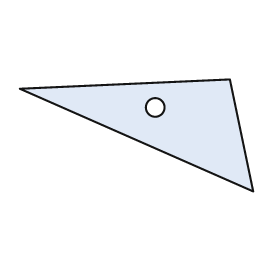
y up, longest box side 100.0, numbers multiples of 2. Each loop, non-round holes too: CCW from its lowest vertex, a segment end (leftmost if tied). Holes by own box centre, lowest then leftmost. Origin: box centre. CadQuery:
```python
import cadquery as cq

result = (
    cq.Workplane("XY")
    .moveTo(50.0, -24.0)
    .lineTo(40.0, 24.0)
    .lineTo(-50.0, 20.0)
    .close()
    .moveTo(8.0, 12.0)
    .circle(4.0)
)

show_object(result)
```